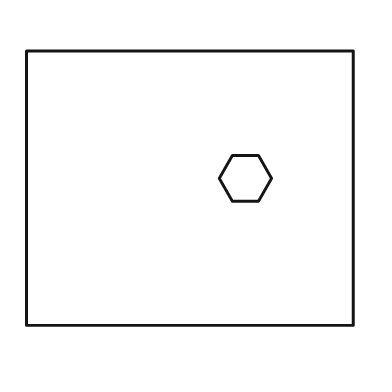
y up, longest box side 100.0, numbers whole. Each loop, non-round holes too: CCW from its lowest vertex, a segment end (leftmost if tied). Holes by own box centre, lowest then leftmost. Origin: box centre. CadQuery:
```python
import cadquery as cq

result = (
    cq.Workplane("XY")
    .moveTo(-50.0, -42.0)
    .lineTo(50.0, -42.0)
    .lineTo(50.0, 42.0)
    .lineTo(-50.0, 42.0)
    .close()
    .moveTo(13.0, -4.0)
    .lineTo(21.0, -4.0)
    .lineTo(25.0, 3.0)
    .lineTo(21.0, 10.0)
    .lineTo(13.0, 10.0)
    .lineTo(9.0, 3.0)
    .close()
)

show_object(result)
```